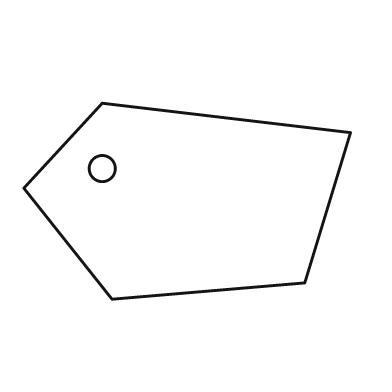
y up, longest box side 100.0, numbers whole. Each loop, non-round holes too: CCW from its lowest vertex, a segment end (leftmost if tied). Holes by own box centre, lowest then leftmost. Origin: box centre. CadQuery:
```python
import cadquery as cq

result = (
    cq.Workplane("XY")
    .moveTo(-23.0, -30.0)
    .lineTo(36.0, -25.0)
    .lineTo(50.0, 21.0)
    .lineTo(-26.0, 30.0)
    .lineTo(-50.0, 4.0)
    .close()
    .moveTo(-26.0, 10.0)
    .circle(4.0)
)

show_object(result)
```